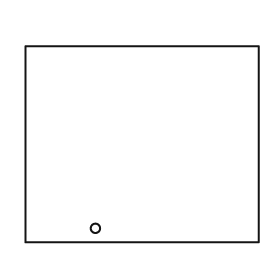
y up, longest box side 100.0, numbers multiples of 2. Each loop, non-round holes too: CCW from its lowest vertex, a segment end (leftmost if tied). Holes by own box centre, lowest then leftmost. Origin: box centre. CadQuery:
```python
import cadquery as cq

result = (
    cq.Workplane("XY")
    .moveTo(-50.0, -42.0)
    .lineTo(50.0, -42.0)
    .lineTo(50.0, 42.0)
    .lineTo(-50.0, 42.0)
    .close()
    .moveTo(-20.0, -36.0)
    .circle(2.0)
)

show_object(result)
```